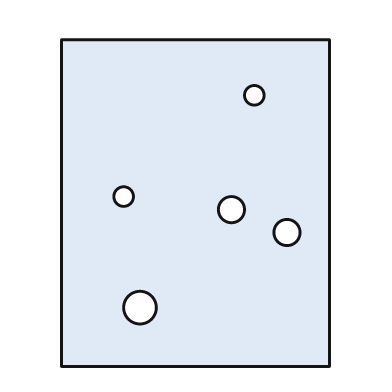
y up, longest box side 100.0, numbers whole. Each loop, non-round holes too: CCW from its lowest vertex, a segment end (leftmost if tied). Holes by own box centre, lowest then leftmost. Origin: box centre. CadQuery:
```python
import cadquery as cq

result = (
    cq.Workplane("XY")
    .moveTo(-41.0, -50.0)
    .lineTo(41.0, -50.0)
    .lineTo(41.0, 50.0)
    .lineTo(-41.0, 50.0)
    .close()
    .moveTo(-17.0, -32.0)
    .circle(5.0)
    .moveTo(28.0, -9.0)
    .circle(4.0)
    .moveTo(11.0, -2.0)
    .circle(4.0)
    .moveTo(-22.0, 2.0)
    .circle(3.0)
    .moveTo(18.0, 33.0)
    .circle(3.0)
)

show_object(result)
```